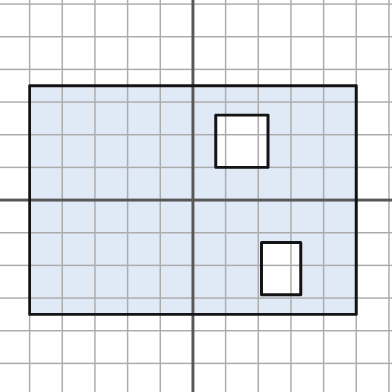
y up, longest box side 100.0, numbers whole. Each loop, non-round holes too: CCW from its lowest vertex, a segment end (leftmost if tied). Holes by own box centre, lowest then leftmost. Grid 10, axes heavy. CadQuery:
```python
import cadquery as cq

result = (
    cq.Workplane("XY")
    .moveTo(-50.0, -35.0)
    .lineTo(50.0, -35.0)
    .lineTo(50.0, 35.0)
    .lineTo(-50.0, 35.0)
    .close()
    .moveTo(21.0, -29.0)
    .lineTo(33.0, -29.0)
    .lineTo(33.0, -13.0)
    .lineTo(21.0, -13.0)
    .close()
    .moveTo(7.0, 10.0)
    .lineTo(23.0, 10.0)
    .lineTo(23.0, 26.0)
    .lineTo(7.0, 26.0)
    .close()
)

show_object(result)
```